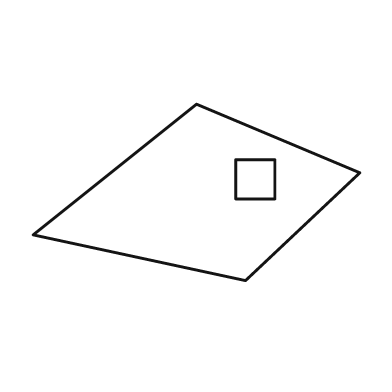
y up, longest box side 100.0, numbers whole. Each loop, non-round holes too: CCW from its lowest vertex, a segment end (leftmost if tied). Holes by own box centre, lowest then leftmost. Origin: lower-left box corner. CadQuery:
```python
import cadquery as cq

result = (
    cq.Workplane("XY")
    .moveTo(65.0, 0.0)
    .lineTo(100.0, 33.0)
    .lineTo(50.0, 54.0)
    .lineTo(0.0, 14.0)
    .close()
    .moveTo(62.0, 25.0)
    .lineTo(74.0, 25.0)
    .lineTo(74.0, 37.0)
    .lineTo(62.0, 37.0)
    .close()
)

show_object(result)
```